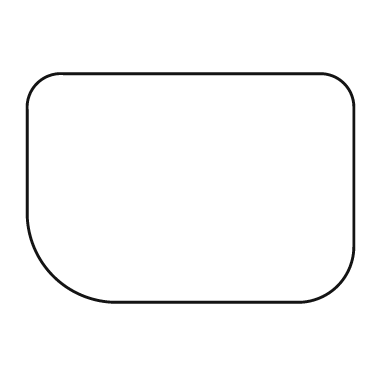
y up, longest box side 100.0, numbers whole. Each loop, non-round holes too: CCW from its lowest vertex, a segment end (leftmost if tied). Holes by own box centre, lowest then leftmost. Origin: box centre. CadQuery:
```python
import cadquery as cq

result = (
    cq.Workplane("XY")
    .moveTo(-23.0, -35.0)
    .lineTo(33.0, -35.0)
    .threePointArc((45.0, -30.0), (50.0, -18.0))
    .lineTo(50.0, 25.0)
    .threePointArc((47.0, 32.0), (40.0, 35.0))
    .lineTo(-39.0, 35.0)
    .threePointArc((-47.0, 32.0), (-50.0, 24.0))
    .lineTo(-50.0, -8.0)
    .threePointArc((-42.0, -27.0), (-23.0, -35.0))
    .close()
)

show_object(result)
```